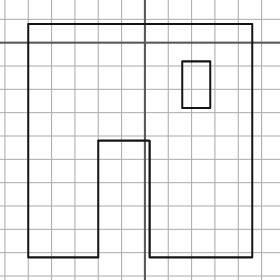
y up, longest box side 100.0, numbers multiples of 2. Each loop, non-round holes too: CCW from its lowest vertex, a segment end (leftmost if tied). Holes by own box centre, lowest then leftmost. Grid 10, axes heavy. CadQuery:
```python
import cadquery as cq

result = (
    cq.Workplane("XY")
    .moveTo(-50.0, -92.0)
    .lineTo(-20.0, -92.0)
    .lineTo(-20.0, -42.0)
    .lineTo(2.0, -42.0)
    .lineTo(2.0, -92.0)
    .lineTo(46.0, -92.0)
    .lineTo(46.0, 8.0)
    .lineTo(-50.0, 8.0)
    .close()
    .moveTo(16.0, -28.0)
    .lineTo(28.0, -28.0)
    .lineTo(28.0, -8.0)
    .lineTo(16.0, -8.0)
    .close()
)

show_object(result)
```